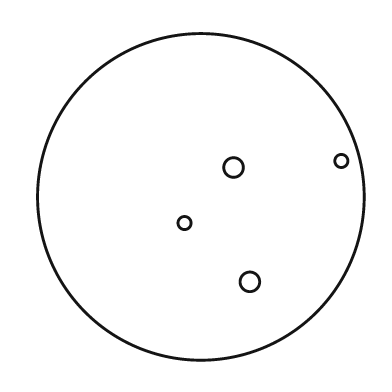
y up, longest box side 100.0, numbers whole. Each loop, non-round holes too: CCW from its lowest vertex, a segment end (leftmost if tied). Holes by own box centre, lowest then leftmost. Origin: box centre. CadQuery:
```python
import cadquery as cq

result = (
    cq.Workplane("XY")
    .moveTo(0.0, 0.0)
    .circle(50.0)
    .moveTo(15.0, -26.0)
    .circle(3.0)
    .moveTo(-5.0, -8.0)
    .circle(2.0)
    .moveTo(10.0, 9.0)
    .circle(3.0)
    .moveTo(43.0, 11.0)
    .circle(2.0)
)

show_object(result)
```